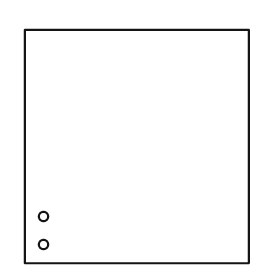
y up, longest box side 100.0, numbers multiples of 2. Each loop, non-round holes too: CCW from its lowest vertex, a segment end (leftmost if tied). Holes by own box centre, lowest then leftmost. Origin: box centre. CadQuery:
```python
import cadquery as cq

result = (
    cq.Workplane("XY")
    .moveTo(-48.0, -50.0)
    .lineTo(48.0, -50.0)
    .lineTo(48.0, 50.0)
    .lineTo(-48.0, 50.0)
    .close()
    .moveTo(-40.0, -42.0)
    .circle(2.0)
    .moveTo(-40.0, -30.0)
    .circle(2.0)
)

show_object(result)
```